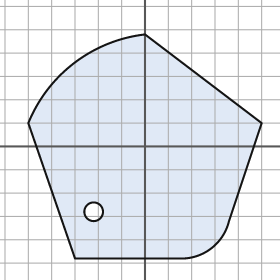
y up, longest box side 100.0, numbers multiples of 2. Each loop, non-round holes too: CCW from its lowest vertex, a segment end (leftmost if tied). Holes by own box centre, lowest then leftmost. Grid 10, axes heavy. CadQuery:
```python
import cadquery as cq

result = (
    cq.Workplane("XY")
    .moveTo(-30.0, -48.0)
    .lineTo(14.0, -48.0)
    .threePointArc((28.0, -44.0), (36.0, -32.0))
    .lineTo(50.0, 10.0)
    .lineTo(0.0, 48.0)
    .threePointArc((-30.0, 36.0), (-50.0, 10.0))
    .close()
    .moveTo(-22.0, -28.0)
    .circle(4.0)
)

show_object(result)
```